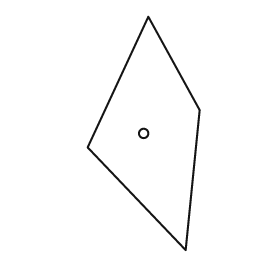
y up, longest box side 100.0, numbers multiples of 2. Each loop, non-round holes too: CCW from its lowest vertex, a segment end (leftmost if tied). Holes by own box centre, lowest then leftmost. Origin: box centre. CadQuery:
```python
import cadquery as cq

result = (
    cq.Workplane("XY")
    .moveTo(18.0, -50.0)
    .lineTo(24.0, 10.0)
    .lineTo(2.0, 50.0)
    .lineTo(-24.0, -6.0)
    .close()
    .moveTo(0.0, 0.0)
    .circle(2.0)
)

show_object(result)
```